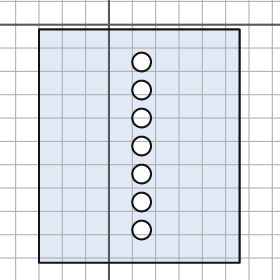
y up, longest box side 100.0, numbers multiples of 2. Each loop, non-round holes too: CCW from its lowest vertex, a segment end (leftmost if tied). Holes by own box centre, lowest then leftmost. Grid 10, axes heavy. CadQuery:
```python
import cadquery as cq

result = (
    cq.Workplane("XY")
    .moveTo(-30.0, -102.0)
    .lineTo(56.0, -102.0)
    .lineTo(56.0, -2.0)
    .lineTo(-30.0, -2.0)
    .close()
    .moveTo(14.0, -88.0)
    .circle(4.0)
    .moveTo(14.0, -76.0)
    .circle(4.0)
    .moveTo(14.0, -64.0)
    .circle(4.0)
    .moveTo(14.0, -52.0)
    .circle(4.0)
    .moveTo(14.0, -40.0)
    .circle(4.0)
    .moveTo(14.0, -28.0)
    .circle(4.0)
    .moveTo(14.0, -16.0)
    .circle(4.0)
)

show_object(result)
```